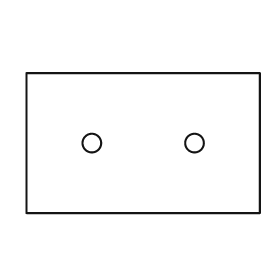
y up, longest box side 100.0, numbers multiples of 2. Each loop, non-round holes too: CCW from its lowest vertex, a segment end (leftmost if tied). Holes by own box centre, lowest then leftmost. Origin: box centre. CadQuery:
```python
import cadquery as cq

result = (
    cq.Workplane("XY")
    .moveTo(-50.0, -30.0)
    .lineTo(50.0, -30.0)
    .lineTo(50.0, 30.0)
    .lineTo(-50.0, 30.0)
    .close()
    .moveTo(-22.0, 0.0)
    .circle(4.0)
    .moveTo(22.0, 0.0)
    .circle(4.0)
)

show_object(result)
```